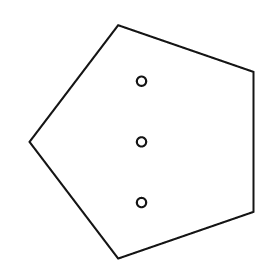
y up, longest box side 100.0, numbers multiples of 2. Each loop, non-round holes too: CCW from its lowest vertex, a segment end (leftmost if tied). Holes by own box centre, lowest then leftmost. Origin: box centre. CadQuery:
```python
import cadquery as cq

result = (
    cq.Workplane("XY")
    .moveTo(-10.0, -50.0)
    .lineTo(48.0, -30.0)
    .lineTo(48.0, 30.0)
    .lineTo(-10.0, 50.0)
    .lineTo(-48.0, 0.0)
    .close()
    .moveTo(0.0, -26.0)
    .circle(2.0)
    .moveTo(0.0, 0.0)
    .circle(2.0)
    .moveTo(0.0, 26.0)
    .circle(2.0)
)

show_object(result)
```